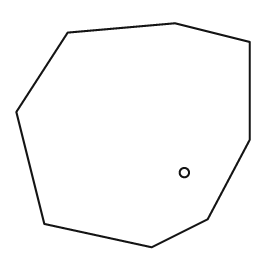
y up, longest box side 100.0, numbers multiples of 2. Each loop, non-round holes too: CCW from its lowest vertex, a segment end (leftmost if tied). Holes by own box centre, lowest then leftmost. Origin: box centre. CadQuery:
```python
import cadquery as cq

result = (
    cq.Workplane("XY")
    .moveTo(8.0, -48.0)
    .lineTo(32.0, -36.0)
    .lineTo(50.0, -2.0)
    .lineTo(50.0, 40.0)
    .lineTo(18.0, 48.0)
    .lineTo(-28.0, 44.0)
    .lineTo(-50.0, 10.0)
    .lineTo(-38.0, -38.0)
    .close()
    .moveTo(22.0, -16.0)
    .circle(2.0)
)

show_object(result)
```